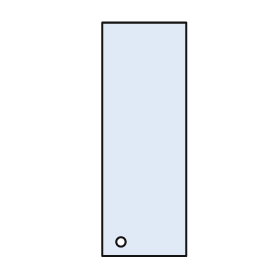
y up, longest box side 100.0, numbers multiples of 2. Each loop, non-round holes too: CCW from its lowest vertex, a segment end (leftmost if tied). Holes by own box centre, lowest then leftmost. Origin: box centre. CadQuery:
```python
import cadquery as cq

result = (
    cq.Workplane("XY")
    .moveTo(-18.0, -50.0)
    .lineTo(18.0, -50.0)
    .lineTo(18.0, 50.0)
    .lineTo(-18.0, 50.0)
    .close()
    .moveTo(-10.0, -44.0)
    .circle(2.0)
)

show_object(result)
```